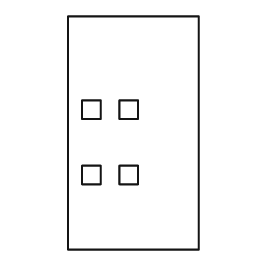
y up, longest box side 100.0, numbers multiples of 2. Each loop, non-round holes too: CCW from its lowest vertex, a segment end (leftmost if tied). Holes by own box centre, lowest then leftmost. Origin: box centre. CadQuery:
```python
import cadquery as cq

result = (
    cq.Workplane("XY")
    .moveTo(-28.0, -50.0)
    .lineTo(28.0, -50.0)
    .lineTo(28.0, 50.0)
    .lineTo(-28.0, 50.0)
    .close()
    .moveTo(-22.0, -22.0)
    .lineTo(-14.0, -22.0)
    .lineTo(-14.0, -14.0)
    .lineTo(-22.0, -14.0)
    .close()
    .moveTo(-6.0, -22.0)
    .lineTo(2.0, -22.0)
    .lineTo(2.0, -14.0)
    .lineTo(-6.0, -14.0)
    .close()
    .moveTo(-22.0, 6.0)
    .lineTo(-14.0, 6.0)
    .lineTo(-14.0, 14.0)
    .lineTo(-22.0, 14.0)
    .close()
    .moveTo(-6.0, 6.0)
    .lineTo(2.0, 6.0)
    .lineTo(2.0, 14.0)
    .lineTo(-6.0, 14.0)
    .close()
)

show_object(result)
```